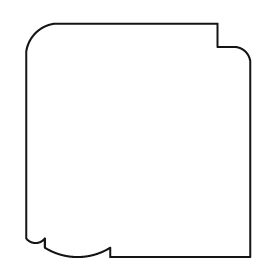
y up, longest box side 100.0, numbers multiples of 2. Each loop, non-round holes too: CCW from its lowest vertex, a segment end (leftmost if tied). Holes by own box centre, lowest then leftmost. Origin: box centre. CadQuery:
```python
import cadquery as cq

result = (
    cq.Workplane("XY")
    .moveTo(-12.0, -50.0)
    .lineTo(48.0, -50.0)
    .lineTo(48.0, 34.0)
    .threePointArc((46.0, 38.0), (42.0, 40.0))
    .lineTo(34.0, 40.0)
    .lineTo(34.0, 50.0)
    .lineTo(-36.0, 50.0)
    .threePointArc((-44.0, 46.0), (-48.0, 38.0))
    .lineTo(-48.0, -42.0)
    .threePointArc((-44.0, -44.0), (-40.0, -42.0))
    .lineTo(-40.0, -46.0)
    .threePointArc((-26.0, -50.0), (-12.0, -46.0))
    .close()
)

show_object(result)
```